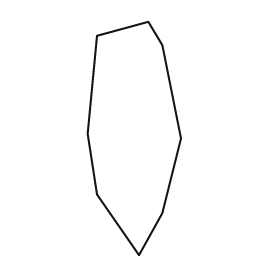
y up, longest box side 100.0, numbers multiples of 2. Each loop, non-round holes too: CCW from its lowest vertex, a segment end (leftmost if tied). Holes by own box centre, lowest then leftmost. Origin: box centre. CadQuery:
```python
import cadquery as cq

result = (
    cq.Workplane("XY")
    .moveTo(2.0, -50.0)
    .lineTo(12.0, -32.0)
    .lineTo(20.0, 0.0)
    .lineTo(12.0, 40.0)
    .lineTo(6.0, 50.0)
    .lineTo(-16.0, 44.0)
    .lineTo(-20.0, 2.0)
    .lineTo(-16.0, -24.0)
    .close()
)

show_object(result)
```